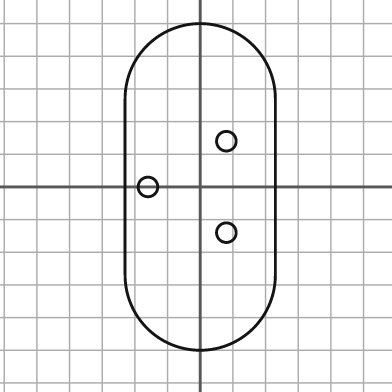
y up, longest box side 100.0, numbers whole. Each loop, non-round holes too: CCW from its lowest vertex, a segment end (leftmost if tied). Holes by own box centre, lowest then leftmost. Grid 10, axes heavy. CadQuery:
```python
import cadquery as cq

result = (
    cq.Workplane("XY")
    .moveTo(-23.0, -27.0)
    .threePointArc((0.0, -50.0), (23.0, -27.0))
    .lineTo(23.0, 27.0)
    .threePointArc((0.0, 50.0), (-23.0, 27.0))
    .close()
    .moveTo(8.0, -14.0)
    .circle(3.0)
    .moveTo(-16.0, 0.0)
    .circle(3.0)
    .moveTo(8.0, 14.0)
    .circle(3.0)
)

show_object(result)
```